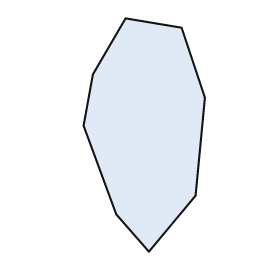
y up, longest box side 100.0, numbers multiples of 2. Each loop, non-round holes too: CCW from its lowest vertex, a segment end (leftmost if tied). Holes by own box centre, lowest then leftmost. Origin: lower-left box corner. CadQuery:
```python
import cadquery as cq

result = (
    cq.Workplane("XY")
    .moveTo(28.0, 0.0)
    .lineTo(48.0, 24.0)
    .lineTo(52.0, 66.0)
    .lineTo(42.0, 96.0)
    .lineTo(18.0, 100.0)
    .lineTo(4.0, 76.0)
    .lineTo(0.0, 54.0)
    .lineTo(14.0, 16.0)
    .close()
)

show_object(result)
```